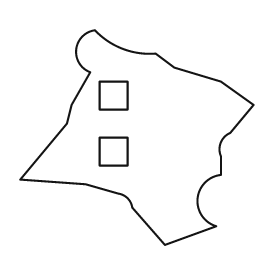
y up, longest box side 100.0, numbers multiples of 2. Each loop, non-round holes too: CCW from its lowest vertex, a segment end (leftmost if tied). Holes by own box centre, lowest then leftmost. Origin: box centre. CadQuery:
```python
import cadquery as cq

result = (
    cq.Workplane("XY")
    .moveTo(12.0, -46.0)
    .lineTo(34.0, -38.0)
    .threePointArc((26.0, -26.0), (36.0, -16.0))
    .lineTo(36.0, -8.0)
    .threePointArc((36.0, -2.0), (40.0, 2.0))
    .lineTo(50.0, 14.0)
    .lineTo(36.0, 24.0)
    .lineTo(16.0, 30.0)
    .lineTo(8.0, 36.0)
    .threePointArc((-6.0, 38.0), (-18.0, 46.0))
    .threePointArc((-26.0, 38.0), (-20.0, 28.0))
    .lineTo(-28.0, 14.0)
    .lineTo(-30.0, 6.0)
    .lineTo(-50.0, -18.0)
    .lineTo(-22.0, -20.0)
    .lineTo(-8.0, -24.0)
    .threePointArc((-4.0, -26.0), (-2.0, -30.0))
    .close()
    .moveTo(-16.0, -12.0)
    .lineTo(-4.0, -12.0)
    .lineTo(-4.0, 0.0)
    .lineTo(-16.0, 0.0)
    .close()
    .moveTo(-16.0, 12.0)
    .lineTo(-4.0, 12.0)
    .lineTo(-4.0, 24.0)
    .lineTo(-16.0, 24.0)
    .close()
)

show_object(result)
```